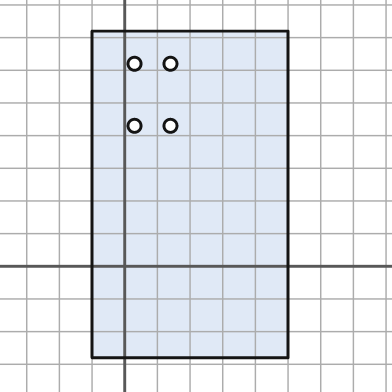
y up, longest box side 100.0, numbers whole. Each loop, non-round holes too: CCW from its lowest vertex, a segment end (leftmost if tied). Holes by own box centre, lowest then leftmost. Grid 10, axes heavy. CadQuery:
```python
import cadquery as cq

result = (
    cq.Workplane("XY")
    .moveTo(-10.0, -28.0)
    .lineTo(50.0, -28.0)
    .lineTo(50.0, 72.0)
    .lineTo(-10.0, 72.0)
    .close()
    .moveTo(3.0, 43.0)
    .circle(2.0)
    .moveTo(14.0, 43.0)
    .circle(2.0)
    .moveTo(3.0, 62.0)
    .circle(2.0)
    .moveTo(14.0, 62.0)
    .circle(2.0)
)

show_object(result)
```